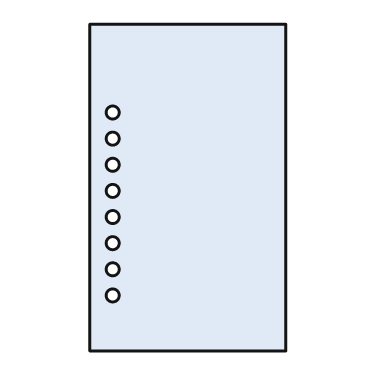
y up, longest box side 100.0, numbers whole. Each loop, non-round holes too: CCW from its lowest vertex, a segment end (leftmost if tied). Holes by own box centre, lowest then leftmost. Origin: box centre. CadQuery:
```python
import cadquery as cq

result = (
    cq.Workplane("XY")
    .moveTo(-30.0, -50.0)
    .lineTo(30.0, -50.0)
    .lineTo(30.0, 50.0)
    .lineTo(-30.0, 50.0)
    .close()
    .moveTo(-23.0, -33.0)
    .circle(2.0)
    .moveTo(-23.0, -25.0)
    .circle(2.0)
    .moveTo(-23.0, -17.0)
    .circle(2.0)
    .moveTo(-23.0, -9.0)
    .circle(2.0)
    .moveTo(-23.0, -1.0)
    .circle(2.0)
    .moveTo(-23.0, 7.0)
    .circle(2.0)
    .moveTo(-23.0, 15.0)
    .circle(2.0)
    .moveTo(-23.0, 23.0)
    .circle(2.0)
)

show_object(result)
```